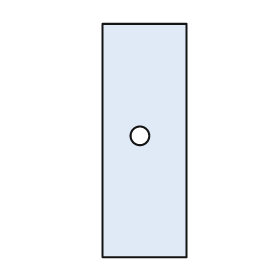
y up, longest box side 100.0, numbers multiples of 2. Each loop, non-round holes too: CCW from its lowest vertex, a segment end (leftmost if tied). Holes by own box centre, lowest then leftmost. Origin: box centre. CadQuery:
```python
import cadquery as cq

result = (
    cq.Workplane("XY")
    .moveTo(-18.0, -50.0)
    .lineTo(18.0, -50.0)
    .lineTo(18.0, 50.0)
    .lineTo(-18.0, 50.0)
    .close()
    .moveTo(-2.0, 2.0)
    .circle(4.0)
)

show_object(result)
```